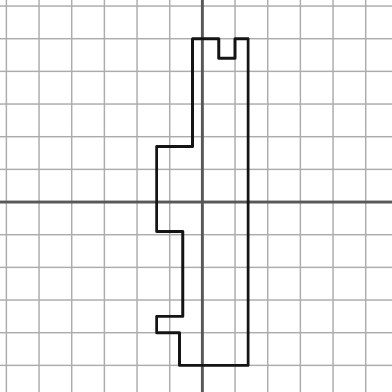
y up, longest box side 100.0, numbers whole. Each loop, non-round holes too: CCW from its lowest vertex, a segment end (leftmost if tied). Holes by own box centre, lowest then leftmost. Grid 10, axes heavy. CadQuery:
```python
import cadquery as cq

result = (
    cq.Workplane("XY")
    .moveTo(-7.0, -50.0)
    .lineTo(14.0, -50.0)
    .lineTo(14.0, 50.0)
    .lineTo(10.0, 50.0)
    .lineTo(10.0, 44.0)
    .lineTo(5.0, 44.0)
    .lineTo(5.0, 50.0)
    .lineTo(-3.0, 50.0)
    .lineTo(-3.0, 17.0)
    .lineTo(-14.0, 17.0)
    .lineTo(-14.0, -9.0)
    .lineTo(-6.0, -9.0)
    .lineTo(-6.0, -35.0)
    .lineTo(-14.0, -35.0)
    .lineTo(-14.0, -40.0)
    .lineTo(-7.0, -40.0)
    .close()
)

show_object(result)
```